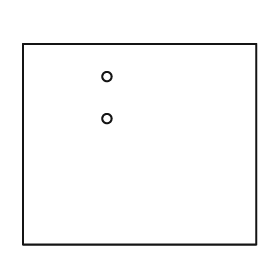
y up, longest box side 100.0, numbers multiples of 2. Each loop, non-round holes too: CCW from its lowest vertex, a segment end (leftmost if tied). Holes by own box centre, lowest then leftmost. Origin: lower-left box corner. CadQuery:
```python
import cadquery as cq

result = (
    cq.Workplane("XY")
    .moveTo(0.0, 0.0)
    .lineTo(100.0, 0.0)
    .lineTo(100.0, 86.0)
    .lineTo(0.0, 86.0)
    .close()
    .moveTo(36.0, 54.0)
    .circle(2.0)
    .moveTo(36.0, 72.0)
    .circle(2.0)
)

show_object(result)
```